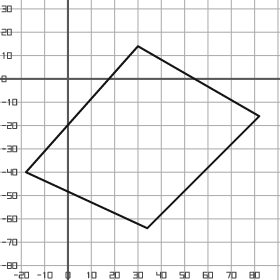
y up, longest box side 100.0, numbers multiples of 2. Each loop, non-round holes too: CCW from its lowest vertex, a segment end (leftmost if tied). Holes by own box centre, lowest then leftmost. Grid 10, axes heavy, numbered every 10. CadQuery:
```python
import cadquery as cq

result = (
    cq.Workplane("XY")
    .moveTo(34.0, -64.0)
    .lineTo(82.0, -16.0)
    .lineTo(30.0, 14.0)
    .lineTo(-18.0, -40.0)
    .close()
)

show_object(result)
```